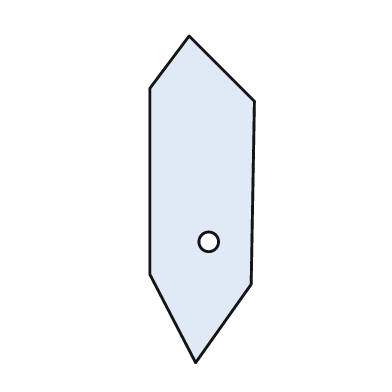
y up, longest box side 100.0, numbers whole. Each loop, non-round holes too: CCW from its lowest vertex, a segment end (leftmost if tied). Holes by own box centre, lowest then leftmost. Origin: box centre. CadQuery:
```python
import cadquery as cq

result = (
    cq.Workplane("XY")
    .moveTo(-2.0, -50.0)
    .lineTo(15.0, -26.0)
    .lineTo(16.0, 30.0)
    .lineTo(-4.0, 50.0)
    .lineTo(-16.0, 34.0)
    .lineTo(-16.0, -23.0)
    .close()
    .moveTo(2.0, -13.0)
    .circle(3.0)
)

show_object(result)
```